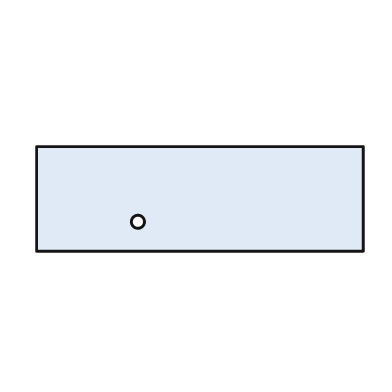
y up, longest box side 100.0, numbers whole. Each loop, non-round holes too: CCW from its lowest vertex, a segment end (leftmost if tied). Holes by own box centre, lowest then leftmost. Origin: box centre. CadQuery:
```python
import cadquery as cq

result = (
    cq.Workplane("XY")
    .moveTo(-50.0, -16.0)
    .lineTo(50.0, -16.0)
    .lineTo(50.0, 16.0)
    .lineTo(-50.0, 16.0)
    .close()
    .moveTo(-19.0, -7.0)
    .circle(2.0)
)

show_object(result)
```